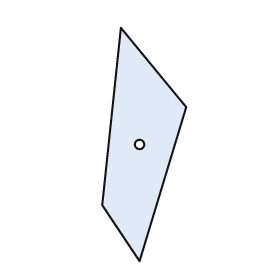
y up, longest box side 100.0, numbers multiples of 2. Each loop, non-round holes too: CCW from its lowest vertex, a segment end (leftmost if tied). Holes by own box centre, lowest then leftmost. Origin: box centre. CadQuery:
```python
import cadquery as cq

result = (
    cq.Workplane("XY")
    .moveTo(-2.0, -50.0)
    .lineTo(18.0, 16.0)
    .lineTo(-10.0, 50.0)
    .lineTo(-18.0, -26.0)
    .close()
    .moveTo(-2.0, 0.0)
    .circle(2.0)
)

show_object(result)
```